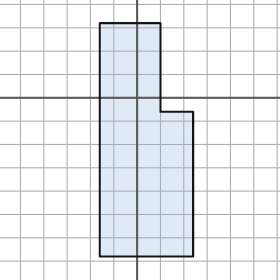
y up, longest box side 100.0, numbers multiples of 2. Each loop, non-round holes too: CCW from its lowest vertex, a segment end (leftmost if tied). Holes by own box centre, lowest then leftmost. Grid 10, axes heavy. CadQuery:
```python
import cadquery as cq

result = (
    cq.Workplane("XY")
    .moveTo(-16.0, -68.0)
    .lineTo(24.0, -68.0)
    .lineTo(24.0, -6.0)
    .lineTo(10.0, -6.0)
    .lineTo(10.0, 32.0)
    .lineTo(-16.0, 32.0)
    .close()
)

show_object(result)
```